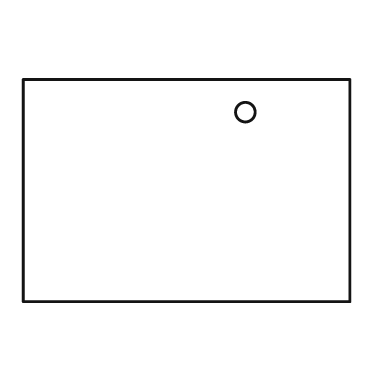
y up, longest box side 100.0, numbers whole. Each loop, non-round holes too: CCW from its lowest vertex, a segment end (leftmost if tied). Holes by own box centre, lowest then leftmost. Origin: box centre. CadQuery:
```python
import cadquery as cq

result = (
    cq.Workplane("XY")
    .moveTo(-50.0, -34.0)
    .lineTo(50.0, -34.0)
    .lineTo(50.0, 34.0)
    .lineTo(-50.0, 34.0)
    .close()
    .moveTo(18.0, 24.0)
    .circle(3.0)
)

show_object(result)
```